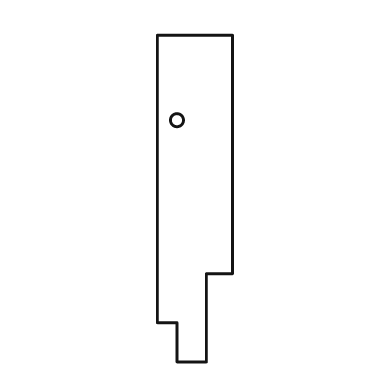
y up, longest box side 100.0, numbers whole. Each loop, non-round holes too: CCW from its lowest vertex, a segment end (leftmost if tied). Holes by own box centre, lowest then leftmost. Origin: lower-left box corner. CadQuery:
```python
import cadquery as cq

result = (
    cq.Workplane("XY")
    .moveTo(6.0, 0.0)
    .lineTo(15.0, 0.0)
    .lineTo(15.0, 27.0)
    .lineTo(23.0, 27.0)
    .lineTo(23.0, 100.0)
    .lineTo(0.0, 100.0)
    .lineTo(0.0, 12.0)
    .lineTo(6.0, 12.0)
    .close()
    .moveTo(6.0, 74.0)
    .circle(2.0)
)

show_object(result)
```